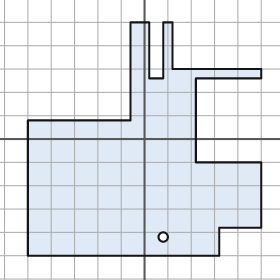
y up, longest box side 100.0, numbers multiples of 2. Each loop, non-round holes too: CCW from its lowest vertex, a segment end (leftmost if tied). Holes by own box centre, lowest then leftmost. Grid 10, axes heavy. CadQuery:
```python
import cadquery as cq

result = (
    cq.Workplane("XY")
    .moveTo(-50.0, -50.0)
    .lineTo(32.0, -50.0)
    .lineTo(32.0, -38.0)
    .lineTo(50.0, -38.0)
    .lineTo(50.0, -10.0)
    .lineTo(22.0, -10.0)
    .lineTo(22.0, 26.0)
    .lineTo(50.0, 26.0)
    .lineTo(50.0, 30.0)
    .lineTo(12.0, 30.0)
    .lineTo(12.0, 50.0)
    .lineTo(8.0, 50.0)
    .lineTo(8.0, 26.0)
    .lineTo(2.0, 26.0)
    .lineTo(2.0, 50.0)
    .lineTo(-6.0, 50.0)
    .lineTo(-6.0, 8.0)
    .lineTo(-50.0, 8.0)
    .close()
    .moveTo(8.0, -42.0)
    .circle(2.0)
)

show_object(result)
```